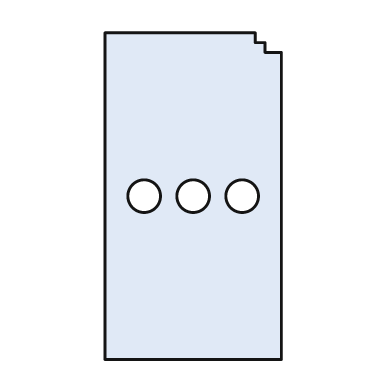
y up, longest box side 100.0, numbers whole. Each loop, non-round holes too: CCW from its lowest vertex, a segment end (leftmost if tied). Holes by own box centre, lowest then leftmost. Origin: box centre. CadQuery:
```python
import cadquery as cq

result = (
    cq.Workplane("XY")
    .moveTo(-27.0, -50.0)
    .lineTo(27.0, -50.0)
    .lineTo(27.0, 44.0)
    .lineTo(22.0, 44.0)
    .lineTo(22.0, 47.0)
    .lineTo(19.0, 47.0)
    .lineTo(19.0, 50.0)
    .lineTo(-27.0, 50.0)
    .close()
    .moveTo(-15.0, 0.0)
    .circle(5.0)
    .moveTo(0.0, 0.0)
    .circle(5.0)
    .moveTo(15.0, 0.0)
    .circle(5.0)
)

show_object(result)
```